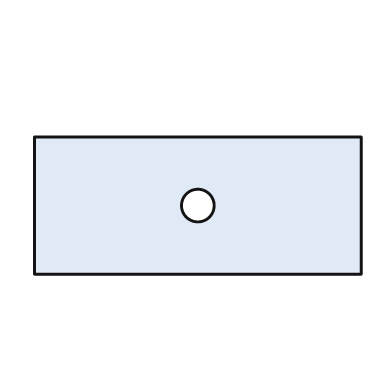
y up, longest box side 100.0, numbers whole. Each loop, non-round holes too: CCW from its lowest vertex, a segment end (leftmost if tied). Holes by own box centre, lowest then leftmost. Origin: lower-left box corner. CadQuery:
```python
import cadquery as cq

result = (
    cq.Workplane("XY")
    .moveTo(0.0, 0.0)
    .lineTo(100.0, 0.0)
    .lineTo(100.0, 42.0)
    .lineTo(0.0, 42.0)
    .close()
    .moveTo(50.0, 21.0)
    .circle(5.0)
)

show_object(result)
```